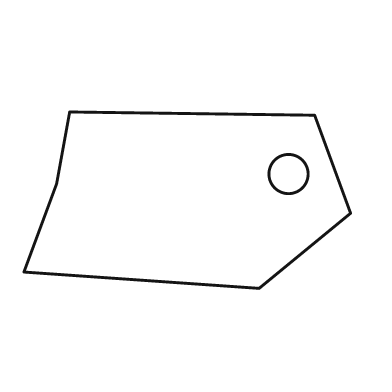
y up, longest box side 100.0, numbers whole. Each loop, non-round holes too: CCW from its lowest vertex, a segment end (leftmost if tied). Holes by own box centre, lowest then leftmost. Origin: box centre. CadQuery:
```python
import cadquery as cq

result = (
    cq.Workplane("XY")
    .moveTo(22.0, -27.0)
    .lineTo(50.0, -4.0)
    .lineTo(39.0, 26.0)
    .lineTo(-36.0, 27.0)
    .lineTo(-40.0, 5.0)
    .lineTo(-50.0, -22.0)
    .close()
    .moveTo(31.0, 8.0)
    .circle(6.0)
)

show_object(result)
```